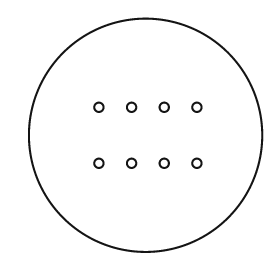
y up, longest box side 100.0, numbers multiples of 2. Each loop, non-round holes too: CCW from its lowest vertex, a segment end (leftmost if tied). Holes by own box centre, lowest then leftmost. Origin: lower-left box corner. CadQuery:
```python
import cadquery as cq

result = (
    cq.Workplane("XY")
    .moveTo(50.0, 50.0)
    .circle(50.0)
    .moveTo(30.0, 38.0)
    .circle(2.0)
    .moveTo(44.0, 38.0)
    .circle(2.0)
    .moveTo(58.0, 38.0)
    .circle(2.0)
    .moveTo(72.0, 38.0)
    .circle(2.0)
    .moveTo(30.0, 62.0)
    .circle(2.0)
    .moveTo(44.0, 62.0)
    .circle(2.0)
    .moveTo(58.0, 62.0)
    .circle(2.0)
    .moveTo(72.0, 62.0)
    .circle(2.0)
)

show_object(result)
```